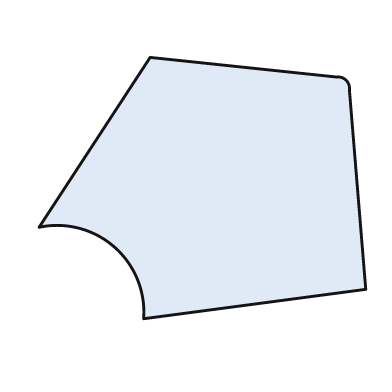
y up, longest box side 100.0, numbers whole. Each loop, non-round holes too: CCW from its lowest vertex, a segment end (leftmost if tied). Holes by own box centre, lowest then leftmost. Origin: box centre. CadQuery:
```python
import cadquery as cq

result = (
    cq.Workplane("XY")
    .moveTo(-18.0, -40.0)
    .lineTo(50.0, -31.0)
    .lineTo(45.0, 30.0)
    .threePointArc((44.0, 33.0), (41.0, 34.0))
    .lineTo(-16.0, 40.0)
    .lineTo(-50.0, -12.0)
    .threePointArc((-27.0, -18.0), (-18.0, -40.0))
    .close()
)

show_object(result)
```